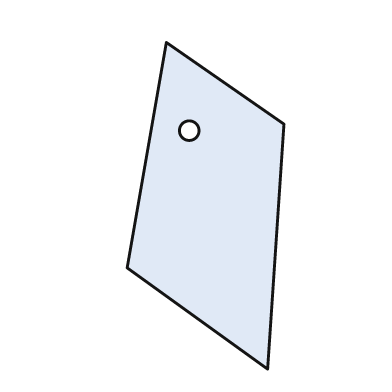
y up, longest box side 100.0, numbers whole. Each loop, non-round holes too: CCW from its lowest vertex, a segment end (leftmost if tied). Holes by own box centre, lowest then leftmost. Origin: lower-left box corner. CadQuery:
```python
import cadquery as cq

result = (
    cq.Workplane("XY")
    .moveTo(43.0, 0.0)
    .lineTo(48.0, 75.0)
    .lineTo(12.0, 100.0)
    .lineTo(0.0, 31.0)
    .close()
    .moveTo(19.0, 73.0)
    .circle(3.0)
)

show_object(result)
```